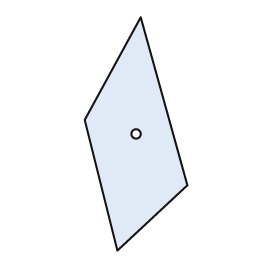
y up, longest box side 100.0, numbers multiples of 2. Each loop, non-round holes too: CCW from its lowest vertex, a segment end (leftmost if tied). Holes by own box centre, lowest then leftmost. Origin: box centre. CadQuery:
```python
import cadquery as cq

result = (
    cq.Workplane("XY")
    .moveTo(-8.0, -50.0)
    .lineTo(22.0, -22.0)
    .lineTo(2.0, 50.0)
    .lineTo(-22.0, 6.0)
    .close()
    .moveTo(0.0, 0.0)
    .circle(2.0)
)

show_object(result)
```